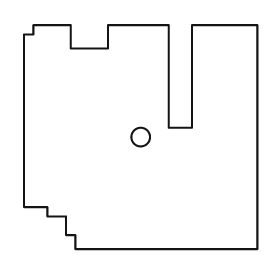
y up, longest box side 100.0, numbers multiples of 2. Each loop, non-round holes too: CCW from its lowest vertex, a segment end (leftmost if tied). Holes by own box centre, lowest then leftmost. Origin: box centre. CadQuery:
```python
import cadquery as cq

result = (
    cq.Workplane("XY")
    .moveTo(-28.0, -48.0)
    .lineTo(50.0, -48.0)
    .lineTo(50.0, 48.0)
    .lineTo(22.0, 48.0)
    .lineTo(22.0, 4.0)
    .lineTo(12.0, 4.0)
    .lineTo(12.0, 48.0)
    .lineTo(-14.0, 48.0)
    .lineTo(-14.0, 38.0)
    .lineTo(-30.0, 38.0)
    .lineTo(-30.0, 48.0)
    .lineTo(-46.0, 48.0)
    .lineTo(-46.0, 44.0)
    .lineTo(-50.0, 44.0)
    .lineTo(-50.0, -30.0)
    .lineTo(-40.0, -30.0)
    .lineTo(-40.0, -34.0)
    .lineTo(-32.0, -34.0)
    .lineTo(-32.0, -42.0)
    .lineTo(-28.0, -42.0)
    .close()
    .moveTo(0.0, 0.0)
    .circle(4.0)
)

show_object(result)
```